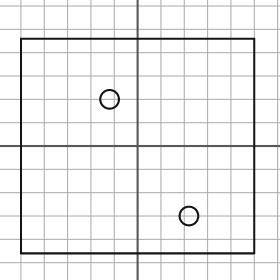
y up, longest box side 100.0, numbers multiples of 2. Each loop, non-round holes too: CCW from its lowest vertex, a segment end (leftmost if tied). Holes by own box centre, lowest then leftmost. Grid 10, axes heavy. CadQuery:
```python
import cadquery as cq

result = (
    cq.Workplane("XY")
    .moveTo(-50.0, -46.0)
    .lineTo(50.0, -46.0)
    .lineTo(50.0, 46.0)
    .lineTo(-50.0, 46.0)
    .close()
    .moveTo(22.0, -30.0)
    .circle(4.0)
    .moveTo(-12.0, 20.0)
    .circle(4.0)
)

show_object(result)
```